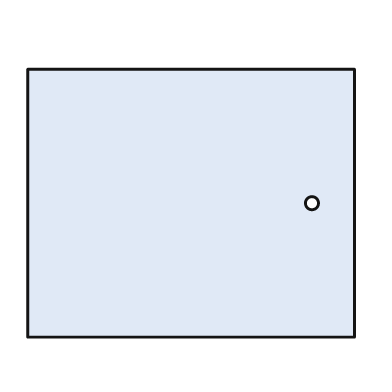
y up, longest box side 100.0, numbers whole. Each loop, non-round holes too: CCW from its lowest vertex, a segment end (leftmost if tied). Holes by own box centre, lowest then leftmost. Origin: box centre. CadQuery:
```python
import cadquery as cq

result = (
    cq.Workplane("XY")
    .moveTo(-50.0, -41.0)
    .lineTo(50.0, -41.0)
    .lineTo(50.0, 41.0)
    .lineTo(-50.0, 41.0)
    .close()
    .moveTo(37.0, 0.0)
    .circle(2.0)
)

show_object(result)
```